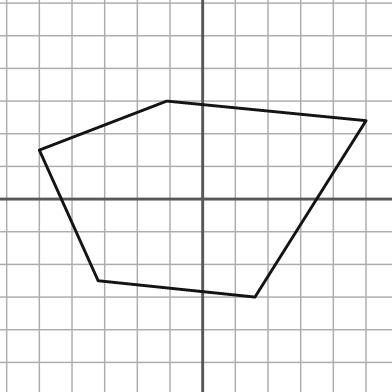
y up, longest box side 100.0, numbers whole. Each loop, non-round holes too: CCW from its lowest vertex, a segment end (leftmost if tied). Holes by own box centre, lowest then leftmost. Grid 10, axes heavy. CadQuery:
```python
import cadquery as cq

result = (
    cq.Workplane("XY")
    .moveTo(16.0, -30.0)
    .lineTo(50.0, 24.0)
    .lineTo(-11.0, 30.0)
    .lineTo(-50.0, 15.0)
    .lineTo(-32.0, -25.0)
    .close()
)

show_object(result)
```